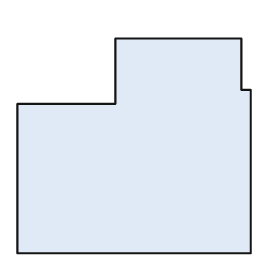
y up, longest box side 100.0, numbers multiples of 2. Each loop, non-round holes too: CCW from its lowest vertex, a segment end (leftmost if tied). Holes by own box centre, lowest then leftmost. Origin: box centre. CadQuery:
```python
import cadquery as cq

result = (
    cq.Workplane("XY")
    .moveTo(-50.0, -46.0)
    .lineTo(50.0, -46.0)
    .lineTo(50.0, 24.0)
    .lineTo(46.0, 24.0)
    .lineTo(46.0, 46.0)
    .lineTo(-8.0, 46.0)
    .lineTo(-8.0, 18.0)
    .lineTo(-50.0, 18.0)
    .close()
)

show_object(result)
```